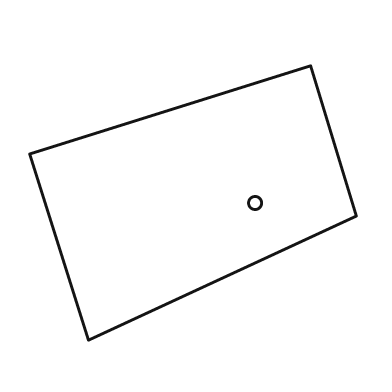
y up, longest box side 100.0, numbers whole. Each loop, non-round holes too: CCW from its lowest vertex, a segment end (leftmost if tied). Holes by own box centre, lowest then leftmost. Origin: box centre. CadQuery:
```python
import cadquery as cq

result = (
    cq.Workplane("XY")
    .moveTo(-32.0, -42.0)
    .lineTo(50.0, -4.0)
    .lineTo(36.0, 42.0)
    .lineTo(-50.0, 15.0)
    .close()
    .moveTo(19.0, 0.0)
    .circle(2.0)
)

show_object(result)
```